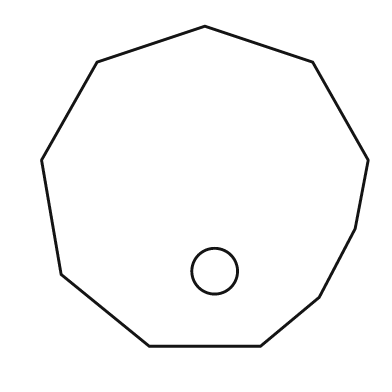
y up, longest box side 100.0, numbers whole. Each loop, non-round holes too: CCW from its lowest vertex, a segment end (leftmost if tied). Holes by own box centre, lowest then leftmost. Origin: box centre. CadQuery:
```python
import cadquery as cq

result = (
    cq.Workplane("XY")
    .moveTo(-17.0, -49.0)
    .lineTo(17.0, -49.0)
    .lineTo(35.0, -34.0)
    .lineTo(46.0, -13.0)
    .lineTo(50.0, 8.0)
    .lineTo(33.0, 38.0)
    .lineTo(0.0, 49.0)
    .lineTo(-33.0, 38.0)
    .lineTo(-50.0, 8.0)
    .lineTo(-44.0, -27.0)
    .close()
    .moveTo(3.0, -26.0)
    .circle(7.0)
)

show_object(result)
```